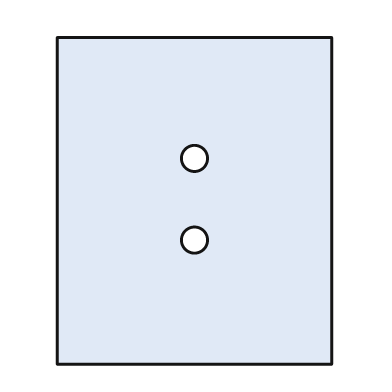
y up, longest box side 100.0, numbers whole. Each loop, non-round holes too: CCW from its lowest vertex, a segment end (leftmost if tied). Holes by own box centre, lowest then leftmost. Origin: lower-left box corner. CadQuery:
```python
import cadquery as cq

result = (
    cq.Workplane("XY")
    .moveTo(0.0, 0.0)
    .lineTo(84.0, 0.0)
    .lineTo(84.0, 100.0)
    .lineTo(0.0, 100.0)
    .close()
    .moveTo(42.0, 38.0)
    .circle(4.0)
    .moveTo(42.0, 63.0)
    .circle(4.0)
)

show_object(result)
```